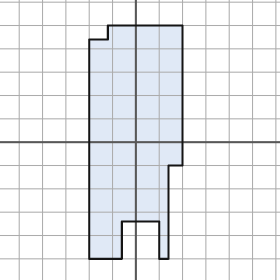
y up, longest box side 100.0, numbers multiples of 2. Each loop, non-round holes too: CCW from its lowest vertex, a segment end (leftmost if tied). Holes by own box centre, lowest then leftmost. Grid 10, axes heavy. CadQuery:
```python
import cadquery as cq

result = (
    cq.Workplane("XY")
    .moveTo(-20.0, -50.0)
    .lineTo(-6.0, -50.0)
    .lineTo(-6.0, -34.0)
    .lineTo(10.0, -34.0)
    .lineTo(10.0, -50.0)
    .lineTo(14.0, -50.0)
    .lineTo(14.0, -10.0)
    .lineTo(20.0, -10.0)
    .lineTo(20.0, 50.0)
    .lineTo(-12.0, 50.0)
    .lineTo(-12.0, 44.0)
    .lineTo(-20.0, 44.0)
    .close()
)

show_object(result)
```